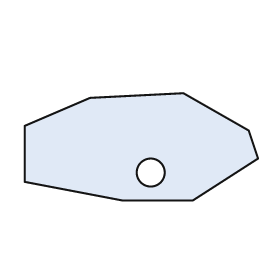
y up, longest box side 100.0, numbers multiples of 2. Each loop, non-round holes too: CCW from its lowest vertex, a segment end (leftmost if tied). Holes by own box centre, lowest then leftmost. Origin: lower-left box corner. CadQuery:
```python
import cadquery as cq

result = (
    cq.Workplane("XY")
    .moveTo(42.0, 0.0)
    .lineTo(72.0, 0.0)
    .lineTo(100.0, 18.0)
    .lineTo(96.0, 30.0)
    .lineTo(68.0, 46.0)
    .lineTo(28.0, 44.0)
    .lineTo(0.0, 32.0)
    .lineTo(0.0, 8.0)
    .close()
    .moveTo(54.0, 12.0)
    .circle(6.0)
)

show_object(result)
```